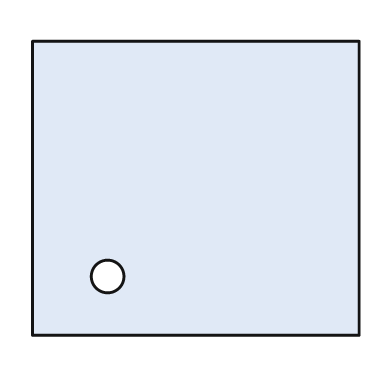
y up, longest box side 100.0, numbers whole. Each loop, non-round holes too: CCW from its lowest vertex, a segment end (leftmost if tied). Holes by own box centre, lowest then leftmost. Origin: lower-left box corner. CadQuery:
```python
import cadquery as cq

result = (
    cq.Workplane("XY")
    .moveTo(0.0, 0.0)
    .lineTo(100.0, 0.0)
    .lineTo(100.0, 90.0)
    .lineTo(0.0, 90.0)
    .close()
    .moveTo(23.0, 18.0)
    .circle(5.0)
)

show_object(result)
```